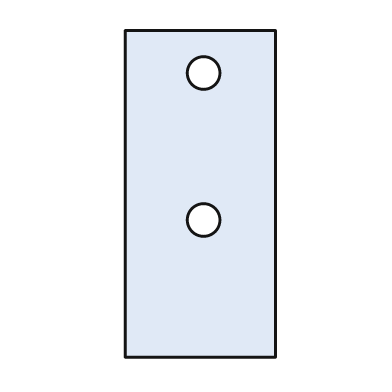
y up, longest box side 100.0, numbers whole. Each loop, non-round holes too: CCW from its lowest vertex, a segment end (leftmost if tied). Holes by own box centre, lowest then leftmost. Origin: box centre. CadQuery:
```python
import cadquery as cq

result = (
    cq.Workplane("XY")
    .moveTo(-23.0, -50.0)
    .lineTo(23.0, -50.0)
    .lineTo(23.0, 50.0)
    .lineTo(-23.0, 50.0)
    .close()
    .moveTo(1.0, -8.0)
    .circle(5.0)
    .moveTo(1.0, 37.0)
    .circle(5.0)
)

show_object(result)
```